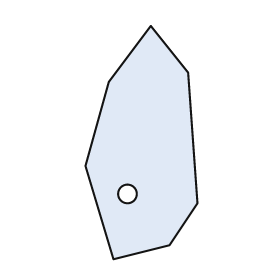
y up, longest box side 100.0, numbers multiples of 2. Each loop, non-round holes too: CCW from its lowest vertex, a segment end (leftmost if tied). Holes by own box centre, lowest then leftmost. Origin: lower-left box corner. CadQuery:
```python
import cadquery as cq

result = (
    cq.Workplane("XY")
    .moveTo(12.0, 0.0)
    .lineTo(36.0, 6.0)
    .lineTo(48.0, 24.0)
    .lineTo(44.0, 80.0)
    .lineTo(28.0, 100.0)
    .lineTo(10.0, 76.0)
    .lineTo(0.0, 40.0)
    .close()
    .moveTo(18.0, 28.0)
    .circle(4.0)
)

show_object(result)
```